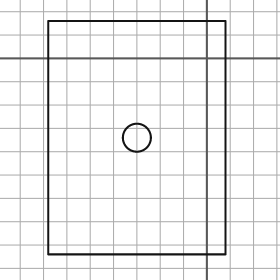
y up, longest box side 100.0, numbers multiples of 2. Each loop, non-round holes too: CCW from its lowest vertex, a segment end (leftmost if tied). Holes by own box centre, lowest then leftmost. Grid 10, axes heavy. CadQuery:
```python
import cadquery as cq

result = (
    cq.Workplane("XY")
    .moveTo(-68.0, -84.0)
    .lineTo(8.0, -84.0)
    .lineTo(8.0, 16.0)
    .lineTo(-68.0, 16.0)
    .close()
    .moveTo(-30.0, -34.0)
    .circle(6.0)
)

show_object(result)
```